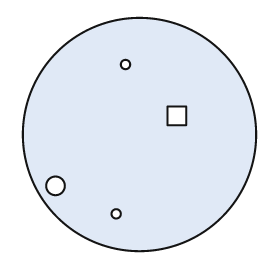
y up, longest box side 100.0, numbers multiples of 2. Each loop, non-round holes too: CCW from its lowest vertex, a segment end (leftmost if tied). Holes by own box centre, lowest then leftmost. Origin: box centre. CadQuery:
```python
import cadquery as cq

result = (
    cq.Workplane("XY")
    .moveTo(0.0, 0.0)
    .circle(50.0)
    .moveTo(-10.0, -34.0)
    .circle(2.0)
    .moveTo(-36.0, -22.0)
    .circle(4.0)
    .moveTo(12.0, 4.0)
    .lineTo(20.0, 4.0)
    .lineTo(20.0, 12.0)
    .lineTo(12.0, 12.0)
    .close()
    .moveTo(-6.0, 30.0)
    .circle(2.0)
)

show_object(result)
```